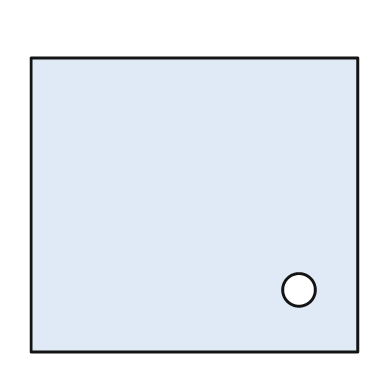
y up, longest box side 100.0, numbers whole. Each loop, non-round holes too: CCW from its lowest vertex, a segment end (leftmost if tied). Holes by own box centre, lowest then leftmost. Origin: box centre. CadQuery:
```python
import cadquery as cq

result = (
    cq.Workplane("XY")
    .moveTo(-50.0, -45.0)
    .lineTo(50.0, -45.0)
    .lineTo(50.0, 45.0)
    .lineTo(-50.0, 45.0)
    .close()
    .moveTo(32.0, -26.0)
    .circle(5.0)
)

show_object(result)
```